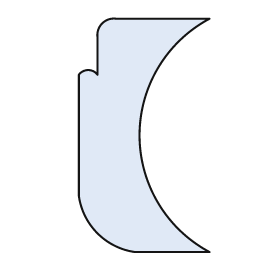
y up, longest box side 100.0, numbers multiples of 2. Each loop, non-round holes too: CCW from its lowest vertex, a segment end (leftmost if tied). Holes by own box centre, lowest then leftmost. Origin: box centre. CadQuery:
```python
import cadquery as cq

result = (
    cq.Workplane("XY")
    .moveTo(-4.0, -50.0)
    .lineTo(28.0, -50.0)
    .threePointArc((-2.0, 0.0), (28.0, 50.0))
    .lineTo(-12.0, 50.0)
    .threePointArc((-18.0, 48.0), (-20.0, 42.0))
    .lineTo(-20.0, 26.0)
    .threePointArc((-24.0, 28.0), (-28.0, 26.0))
    .lineTo(-28.0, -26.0)
    .threePointArc((-20.0, -42.0), (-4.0, -50.0))
    .close()
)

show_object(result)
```